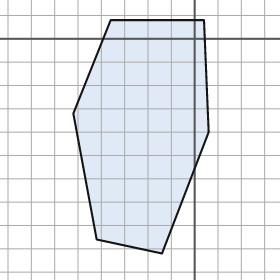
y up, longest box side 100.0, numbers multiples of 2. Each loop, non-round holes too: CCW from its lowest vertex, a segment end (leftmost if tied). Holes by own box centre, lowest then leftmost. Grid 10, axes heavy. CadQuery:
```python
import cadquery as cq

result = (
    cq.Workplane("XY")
    .moveTo(-14.0, -92.0)
    .lineTo(6.0, -40.0)
    .lineTo(4.0, 8.0)
    .lineTo(-36.0, 8.0)
    .lineTo(-52.0, -32.0)
    .lineTo(-42.0, -86.0)
    .close()
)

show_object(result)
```